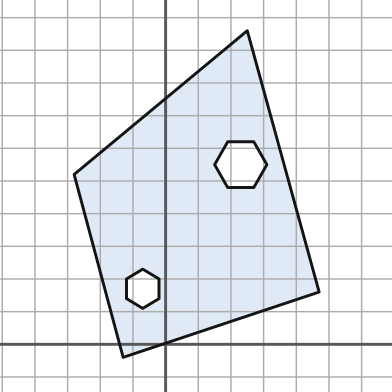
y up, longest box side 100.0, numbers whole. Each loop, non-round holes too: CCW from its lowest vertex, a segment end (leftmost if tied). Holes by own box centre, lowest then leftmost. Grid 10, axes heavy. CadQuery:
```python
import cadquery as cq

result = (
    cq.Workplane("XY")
    .moveTo(-13.0, -4.0)
    .lineTo(47.0, 16.0)
    .lineTo(25.0, 96.0)
    .lineTo(-28.0, 52.0)
    .close()
    .moveTo(-7.0, 11.0)
    .lineTo(-2.0, 14.0)
    .lineTo(-2.0, 20.0)
    .lineTo(-7.0, 23.0)
    .lineTo(-12.0, 20.0)
    .lineTo(-12.0, 14.0)
    .close()
    .moveTo(19.0, 48.0)
    .lineTo(27.0, 48.0)
    .lineTo(31.0, 55.0)
    .lineTo(27.0, 62.0)
    .lineTo(19.0, 62.0)
    .lineTo(15.0, 55.0)
    .close()
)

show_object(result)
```